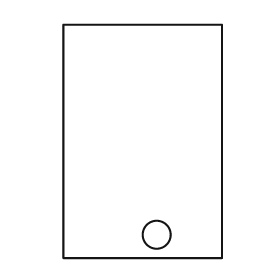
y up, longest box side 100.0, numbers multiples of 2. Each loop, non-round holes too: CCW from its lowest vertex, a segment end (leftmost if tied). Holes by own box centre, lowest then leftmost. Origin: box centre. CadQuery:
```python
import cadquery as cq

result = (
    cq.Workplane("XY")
    .moveTo(-34.0, -50.0)
    .lineTo(34.0, -50.0)
    .lineTo(34.0, 50.0)
    .lineTo(-34.0, 50.0)
    .close()
    .moveTo(6.0, -40.0)
    .circle(6.0)
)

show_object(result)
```